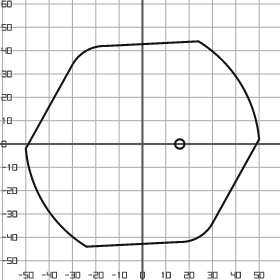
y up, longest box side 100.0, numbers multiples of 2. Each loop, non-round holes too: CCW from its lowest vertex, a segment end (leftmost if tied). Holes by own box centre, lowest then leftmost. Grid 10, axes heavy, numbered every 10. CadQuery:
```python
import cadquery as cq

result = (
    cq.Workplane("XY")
    .moveTo(-24.0, -44.0)
    .lineTo(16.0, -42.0)
    .threePointArc((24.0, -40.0), (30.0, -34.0))
    .lineTo(50.0, 2.0)
    .threePointArc((42.0, 26.0), (24.0, 44.0))
    .lineTo(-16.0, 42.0)
    .threePointArc((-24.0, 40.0), (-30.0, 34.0))
    .lineTo(-50.0, -2.0)
    .threePointArc((-42.0, -26.0), (-24.0, -44.0))
    .close()
    .moveTo(16.0, 0.0)
    .circle(2.0)
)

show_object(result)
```